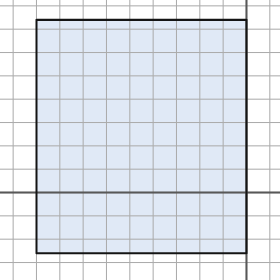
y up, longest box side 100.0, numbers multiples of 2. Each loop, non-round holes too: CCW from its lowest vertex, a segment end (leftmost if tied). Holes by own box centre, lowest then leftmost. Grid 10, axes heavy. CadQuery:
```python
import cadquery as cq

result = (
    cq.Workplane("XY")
    .moveTo(-90.0, -26.0)
    .lineTo(0.0, -26.0)
    .lineTo(0.0, 74.0)
    .lineTo(-90.0, 74.0)
    .close()
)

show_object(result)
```